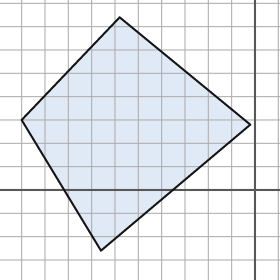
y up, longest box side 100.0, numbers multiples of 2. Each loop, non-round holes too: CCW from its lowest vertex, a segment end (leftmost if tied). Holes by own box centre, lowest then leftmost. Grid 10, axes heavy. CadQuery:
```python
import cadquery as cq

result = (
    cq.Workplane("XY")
    .moveTo(-66.0, -26.0)
    .lineTo(-2.0, 28.0)
    .lineTo(-58.0, 74.0)
    .lineTo(-100.0, 30.0)
    .close()
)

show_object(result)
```